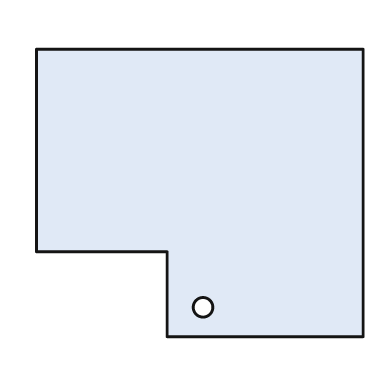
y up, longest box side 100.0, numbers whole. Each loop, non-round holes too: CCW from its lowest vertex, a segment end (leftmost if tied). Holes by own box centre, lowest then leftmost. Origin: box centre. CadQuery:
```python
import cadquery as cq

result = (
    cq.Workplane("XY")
    .moveTo(-10.0, -44.0)
    .lineTo(50.0, -44.0)
    .lineTo(50.0, 44.0)
    .lineTo(-50.0, 44.0)
    .lineTo(-50.0, -18.0)
    .lineTo(-10.0, -18.0)
    .close()
    .moveTo(1.0, -35.0)
    .circle(3.0)
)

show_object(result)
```